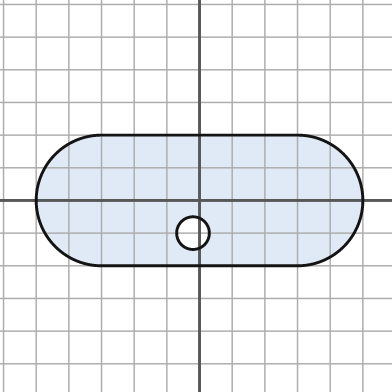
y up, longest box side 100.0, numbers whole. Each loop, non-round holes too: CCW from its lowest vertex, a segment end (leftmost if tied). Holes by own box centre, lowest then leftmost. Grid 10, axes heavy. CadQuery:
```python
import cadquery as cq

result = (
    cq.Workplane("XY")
    .moveTo(-30.0, -20.0)
    .lineTo(30.0, -20.0)
    .threePointArc((50.0, 0.0), (30.0, 20.0))
    .lineTo(-30.0, 20.0)
    .threePointArc((-50.0, 0.0), (-30.0, -20.0))
    .close()
    .moveTo(-2.0, -10.0)
    .circle(5.0)
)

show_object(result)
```